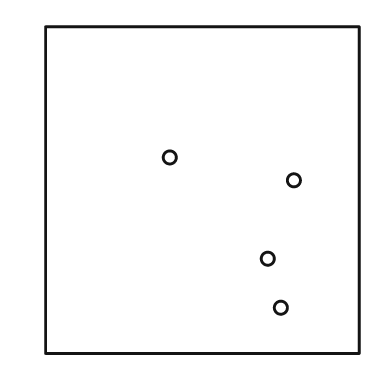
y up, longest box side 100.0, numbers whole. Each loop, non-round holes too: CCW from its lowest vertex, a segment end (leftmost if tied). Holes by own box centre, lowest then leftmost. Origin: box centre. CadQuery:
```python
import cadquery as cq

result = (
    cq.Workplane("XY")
    .moveTo(-48.0, -50.0)
    .lineTo(48.0, -50.0)
    .lineTo(48.0, 50.0)
    .lineTo(-48.0, 50.0)
    .close()
    .moveTo(24.0, -36.0)
    .circle(2.0)
    .moveTo(20.0, -21.0)
    .circle(2.0)
    .moveTo(28.0, 3.0)
    .circle(2.0)
    .moveTo(-10.0, 10.0)
    .circle(2.0)
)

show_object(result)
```